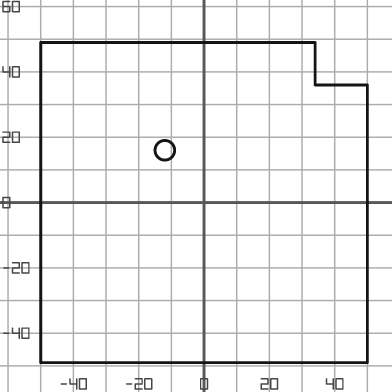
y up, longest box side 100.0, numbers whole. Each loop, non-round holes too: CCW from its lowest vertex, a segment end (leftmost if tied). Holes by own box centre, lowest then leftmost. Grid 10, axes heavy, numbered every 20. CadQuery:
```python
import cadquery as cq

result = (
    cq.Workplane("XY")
    .moveTo(-50.0, -49.0)
    .lineTo(50.0, -49.0)
    .lineTo(50.0, 36.0)
    .lineTo(34.0, 36.0)
    .lineTo(34.0, 49.0)
    .lineTo(-50.0, 49.0)
    .close()
    .moveTo(-12.0, 16.0)
    .circle(3.0)
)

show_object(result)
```